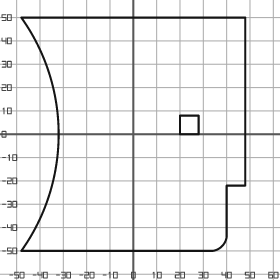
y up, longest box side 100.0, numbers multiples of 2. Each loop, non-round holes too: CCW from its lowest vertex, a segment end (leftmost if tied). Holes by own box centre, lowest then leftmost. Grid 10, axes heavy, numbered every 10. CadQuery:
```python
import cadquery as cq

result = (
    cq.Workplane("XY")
    .moveTo(-48.0, -50.0)
    .lineTo(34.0, -50.0)
    .threePointArc((38.0, -48.0), (40.0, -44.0))
    .lineTo(40.0, -22.0)
    .lineTo(48.0, -22.0)
    .lineTo(48.0, 50.0)
    .lineTo(-48.0, 50.0)
    .threePointArc((-32.0, 0.0), (-48.0, -50.0))
    .close()
    .moveTo(20.0, 0.0)
    .lineTo(28.0, 0.0)
    .lineTo(28.0, 8.0)
    .lineTo(20.0, 8.0)
    .close()
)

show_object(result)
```